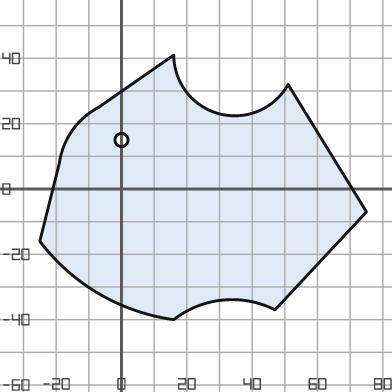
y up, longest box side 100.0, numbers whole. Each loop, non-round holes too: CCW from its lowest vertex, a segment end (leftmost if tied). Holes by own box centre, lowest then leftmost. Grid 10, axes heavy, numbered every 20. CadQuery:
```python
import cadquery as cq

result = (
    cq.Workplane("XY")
    .moveTo(16.0, -40.0)
    .threePointArc((31.0, -34.0), (47.0, -37.0))
    .lineTo(75.0, -7.0)
    .lineTo(51.0, 32.0)
    .threePointArc((30.0, 23.0), (16.0, 41.0))
    .lineTo(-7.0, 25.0)
    .threePointArc((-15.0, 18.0), (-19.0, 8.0))
    .lineTo(-25.0, -16.0)
    .threePointArc((-7.0, -32.0), (16.0, -40.0))
    .close()
    .moveTo(0.0, 15.0)
    .circle(2.0)
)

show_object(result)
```